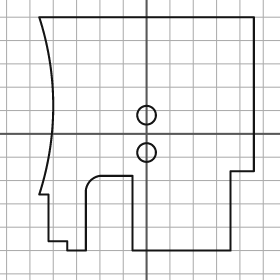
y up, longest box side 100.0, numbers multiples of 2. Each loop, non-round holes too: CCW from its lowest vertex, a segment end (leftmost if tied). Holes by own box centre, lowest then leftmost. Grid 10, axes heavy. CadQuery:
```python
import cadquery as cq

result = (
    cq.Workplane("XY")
    .moveTo(-34.0, -50.0)
    .lineTo(-26.0, -50.0)
    .lineTo(-26.0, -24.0)
    .threePointArc((-24.0, -20.0), (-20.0, -18.0))
    .lineTo(-6.0, -18.0)
    .lineTo(-6.0, -50.0)
    .lineTo(36.0, -50.0)
    .lineTo(36.0, -16.0)
    .lineTo(46.0, -16.0)
    .lineTo(46.0, 50.0)
    .lineTo(-46.0, 50.0)
    .threePointArc((-40.0, 12.0), (-46.0, -26.0))
    .lineTo(-42.0, -26.0)
    .lineTo(-42.0, -46.0)
    .lineTo(-34.0, -46.0)
    .close()
    .moveTo(0.0, -8.0)
    .circle(4.0)
    .moveTo(0.0, 8.0)
    .circle(4.0)
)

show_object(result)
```